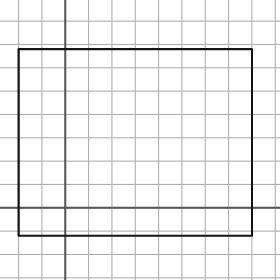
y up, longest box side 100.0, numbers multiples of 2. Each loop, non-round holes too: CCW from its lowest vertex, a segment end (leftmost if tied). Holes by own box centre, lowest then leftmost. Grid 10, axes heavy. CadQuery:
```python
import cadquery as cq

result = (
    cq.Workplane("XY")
    .moveTo(-20.0, -12.0)
    .lineTo(80.0, -12.0)
    .lineTo(80.0, 68.0)
    .lineTo(-20.0, 68.0)
    .close()
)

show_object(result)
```